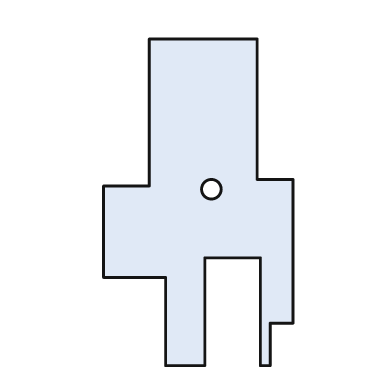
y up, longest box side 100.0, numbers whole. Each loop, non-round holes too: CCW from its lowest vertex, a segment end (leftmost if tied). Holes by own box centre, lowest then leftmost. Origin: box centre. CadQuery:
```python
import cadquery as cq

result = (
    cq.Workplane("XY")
    .moveTo(-10.0, -50.0)
    .lineTo(2.0, -50.0)
    .lineTo(2.0, -17.0)
    .lineTo(19.0, -17.0)
    .lineTo(19.0, -50.0)
    .lineTo(22.0, -50.0)
    .lineTo(22.0, -37.0)
    .lineTo(29.0, -37.0)
    .lineTo(29.0, 7.0)
    .lineTo(18.0, 7.0)
    .lineTo(18.0, 50.0)
    .lineTo(-15.0, 50.0)
    .lineTo(-15.0, 5.0)
    .lineTo(-29.0, 5.0)
    .lineTo(-29.0, -23.0)
    .lineTo(-10.0, -23.0)
    .close()
    .moveTo(4.0, 4.0)
    .circle(3.0)
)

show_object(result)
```